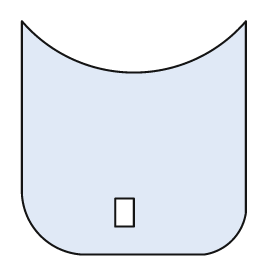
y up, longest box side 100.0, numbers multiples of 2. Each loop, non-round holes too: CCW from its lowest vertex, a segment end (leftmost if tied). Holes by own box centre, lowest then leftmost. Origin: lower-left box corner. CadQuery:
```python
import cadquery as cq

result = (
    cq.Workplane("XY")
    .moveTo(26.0, 0.0)
    .lineTo(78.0, 0.0)
    .threePointArc((90.0, 6.0), (96.0, 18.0))
    .lineTo(96.0, 100.0)
    .threePointArc((48.0, 78.0), (0.0, 100.0))
    .lineTo(0.0, 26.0)
    .threePointArc((8.0, 8.0), (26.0, 0.0))
    .close()
    .moveTo(40.0, 12.0)
    .lineTo(48.0, 12.0)
    .lineTo(48.0, 24.0)
    .lineTo(40.0, 24.0)
    .close()
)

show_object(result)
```